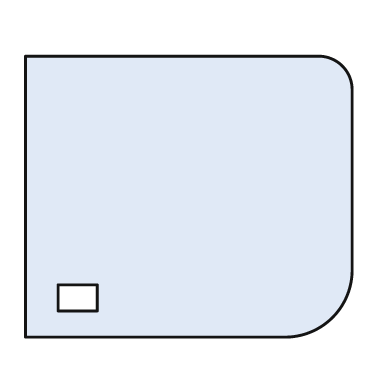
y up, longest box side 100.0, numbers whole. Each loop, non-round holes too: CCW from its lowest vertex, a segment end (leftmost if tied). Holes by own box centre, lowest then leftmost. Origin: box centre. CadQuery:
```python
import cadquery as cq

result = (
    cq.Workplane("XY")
    .moveTo(-50.0, -43.0)
    .lineTo(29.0, -43.0)
    .threePointArc((44.0, -37.0), (50.0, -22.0))
    .lineTo(50.0, 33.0)
    .threePointArc((47.0, 40.0), (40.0, 43.0))
    .lineTo(-50.0, 43.0)
    .close()
    .moveTo(-40.0, -35.0)
    .lineTo(-28.0, -35.0)
    .lineTo(-28.0, -27.0)
    .lineTo(-40.0, -27.0)
    .close()
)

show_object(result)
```